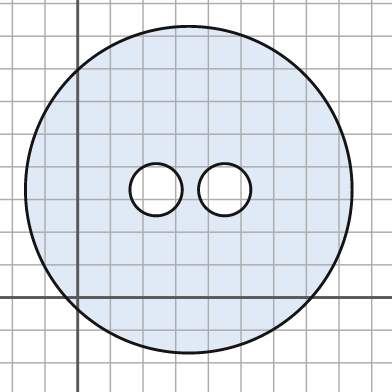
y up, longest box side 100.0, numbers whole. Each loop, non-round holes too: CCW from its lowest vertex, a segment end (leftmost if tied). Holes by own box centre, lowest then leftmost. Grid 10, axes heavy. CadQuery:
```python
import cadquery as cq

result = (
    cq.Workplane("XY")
    .moveTo(34.0, 33.0)
    .circle(50.0)
    .moveTo(24.0, 33.0)
    .circle(8.0)
    .moveTo(45.0, 33.0)
    .circle(8.0)
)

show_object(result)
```